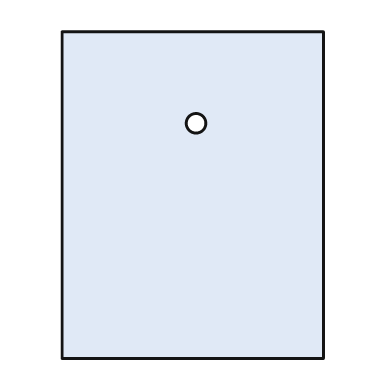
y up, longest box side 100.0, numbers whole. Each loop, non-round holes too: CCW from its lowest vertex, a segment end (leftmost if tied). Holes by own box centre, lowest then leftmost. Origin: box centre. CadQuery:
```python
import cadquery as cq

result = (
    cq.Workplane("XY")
    .moveTo(-40.0, -50.0)
    .lineTo(40.0, -50.0)
    .lineTo(40.0, 50.0)
    .lineTo(-40.0, 50.0)
    .close()
    .moveTo(1.0, 22.0)
    .circle(3.0)
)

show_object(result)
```